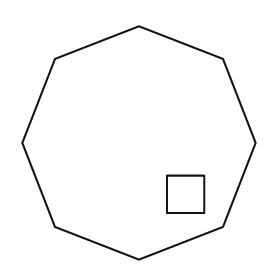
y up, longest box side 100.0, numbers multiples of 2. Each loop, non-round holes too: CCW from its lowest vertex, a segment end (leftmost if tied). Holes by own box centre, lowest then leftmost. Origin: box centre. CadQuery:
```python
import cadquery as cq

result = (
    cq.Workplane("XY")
    .moveTo(0.0, -50.0)
    .lineTo(36.0, -36.0)
    .lineTo(50.0, 0.0)
    .lineTo(36.0, 36.0)
    .lineTo(0.0, 50.0)
    .lineTo(-36.0, 36.0)
    .lineTo(-50.0, 0.0)
    .lineTo(-36.0, -36.0)
    .close()
    .moveTo(12.0, -30.0)
    .lineTo(28.0, -30.0)
    .lineTo(28.0, -14.0)
    .lineTo(12.0, -14.0)
    .close()
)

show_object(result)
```